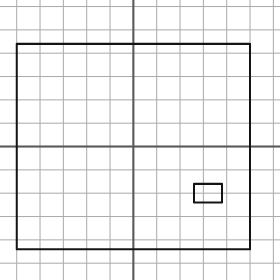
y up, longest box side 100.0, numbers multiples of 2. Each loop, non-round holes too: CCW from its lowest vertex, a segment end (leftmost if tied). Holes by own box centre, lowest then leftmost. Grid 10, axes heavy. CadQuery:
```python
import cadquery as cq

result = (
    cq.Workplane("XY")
    .moveTo(-50.0, -44.0)
    .lineTo(50.0, -44.0)
    .lineTo(50.0, 44.0)
    .lineTo(-50.0, 44.0)
    .close()
    .moveTo(26.0, -24.0)
    .lineTo(38.0, -24.0)
    .lineTo(38.0, -16.0)
    .lineTo(26.0, -16.0)
    .close()
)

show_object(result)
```